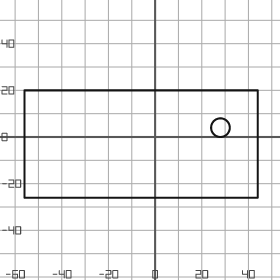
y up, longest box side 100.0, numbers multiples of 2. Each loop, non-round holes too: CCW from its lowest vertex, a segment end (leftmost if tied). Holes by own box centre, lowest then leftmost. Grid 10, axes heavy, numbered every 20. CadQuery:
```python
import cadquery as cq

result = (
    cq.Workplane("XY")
    .moveTo(-56.0, -26.0)
    .lineTo(44.0, -26.0)
    .lineTo(44.0, 20.0)
    .lineTo(-56.0, 20.0)
    .close()
    .moveTo(28.0, 4.0)
    .circle(4.0)
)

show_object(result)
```